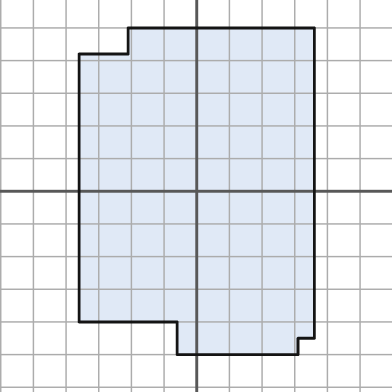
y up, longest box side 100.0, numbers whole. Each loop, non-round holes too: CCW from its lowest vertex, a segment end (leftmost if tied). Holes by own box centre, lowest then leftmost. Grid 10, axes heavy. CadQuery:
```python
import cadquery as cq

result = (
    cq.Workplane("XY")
    .moveTo(-6.0, -50.0)
    .lineTo(31.0, -50.0)
    .lineTo(31.0, -45.0)
    .lineTo(36.0, -45.0)
    .lineTo(36.0, 50.0)
    .lineTo(-21.0, 50.0)
    .lineTo(-21.0, 42.0)
    .lineTo(-36.0, 42.0)
    .lineTo(-36.0, -40.0)
    .lineTo(-6.0, -40.0)
    .close()
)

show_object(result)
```